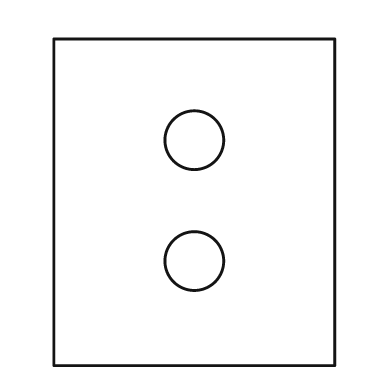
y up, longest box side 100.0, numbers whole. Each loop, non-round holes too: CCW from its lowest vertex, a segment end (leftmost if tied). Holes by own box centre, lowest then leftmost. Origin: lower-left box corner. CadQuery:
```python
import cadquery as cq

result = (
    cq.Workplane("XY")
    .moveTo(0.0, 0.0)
    .lineTo(86.0, 0.0)
    .lineTo(86.0, 100.0)
    .lineTo(0.0, 100.0)
    .close()
    .moveTo(43.0, 32.0)
    .circle(9.0)
    .moveTo(43.0, 69.0)
    .circle(9.0)
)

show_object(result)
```